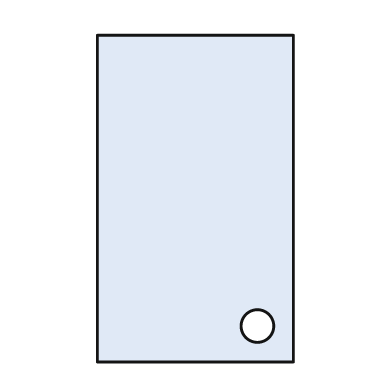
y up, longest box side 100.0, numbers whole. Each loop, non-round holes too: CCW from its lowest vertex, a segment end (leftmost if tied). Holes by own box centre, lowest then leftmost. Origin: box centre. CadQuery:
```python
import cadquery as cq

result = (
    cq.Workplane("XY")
    .moveTo(-30.0, -50.0)
    .lineTo(30.0, -50.0)
    .lineTo(30.0, 50.0)
    .lineTo(-30.0, 50.0)
    .close()
    .moveTo(19.0, -39.0)
    .circle(5.0)
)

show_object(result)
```